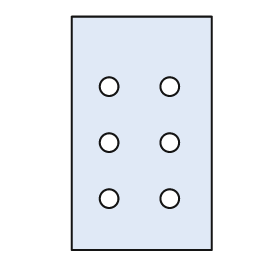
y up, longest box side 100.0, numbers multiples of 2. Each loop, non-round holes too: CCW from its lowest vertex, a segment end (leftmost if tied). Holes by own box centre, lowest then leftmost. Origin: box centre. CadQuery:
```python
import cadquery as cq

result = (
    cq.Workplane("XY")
    .moveTo(-30.0, -50.0)
    .lineTo(30.0, -50.0)
    .lineTo(30.0, 50.0)
    .lineTo(-30.0, 50.0)
    .close()
    .moveTo(-14.0, -28.0)
    .circle(4.0)
    .moveTo(12.0, -28.0)
    .circle(4.0)
    .moveTo(-14.0, -4.0)
    .circle(4.0)
    .moveTo(12.0, -4.0)
    .circle(4.0)
    .moveTo(-14.0, 20.0)
    .circle(4.0)
    .moveTo(12.0, 20.0)
    .circle(4.0)
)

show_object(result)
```